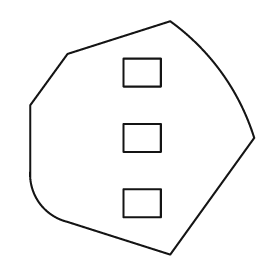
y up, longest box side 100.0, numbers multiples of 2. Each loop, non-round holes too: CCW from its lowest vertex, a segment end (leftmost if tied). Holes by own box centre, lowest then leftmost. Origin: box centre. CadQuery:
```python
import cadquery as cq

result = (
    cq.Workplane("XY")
    .moveTo(12.0, -50.0)
    .lineTo(48.0, 0.0)
    .threePointArc((34.0, 28.0), (12.0, 50.0))
    .lineTo(-32.0, 36.0)
    .lineTo(-48.0, 14.0)
    .lineTo(-48.0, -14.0)
    .threePointArc((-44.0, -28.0), (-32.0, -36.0))
    .close()
    .moveTo(-8.0, -34.0)
    .lineTo(8.0, -34.0)
    .lineTo(8.0, -22.0)
    .lineTo(-8.0, -22.0)
    .close()
    .moveTo(-8.0, -6.0)
    .lineTo(8.0, -6.0)
    .lineTo(8.0, 6.0)
    .lineTo(-8.0, 6.0)
    .close()
    .moveTo(-8.0, 22.0)
    .lineTo(8.0, 22.0)
    .lineTo(8.0, 34.0)
    .lineTo(-8.0, 34.0)
    .close()
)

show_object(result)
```